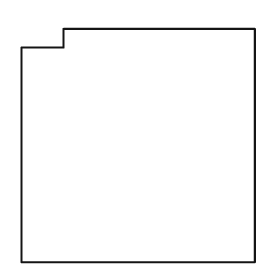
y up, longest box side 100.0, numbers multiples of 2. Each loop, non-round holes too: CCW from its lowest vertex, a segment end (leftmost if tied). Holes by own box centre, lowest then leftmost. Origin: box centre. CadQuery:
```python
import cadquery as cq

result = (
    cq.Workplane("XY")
    .moveTo(-50.0, -50.0)
    .lineTo(50.0, -50.0)
    .lineTo(50.0, 50.0)
    .lineTo(-32.0, 50.0)
    .lineTo(-32.0, 42.0)
    .lineTo(-50.0, 42.0)
    .close()
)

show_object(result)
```